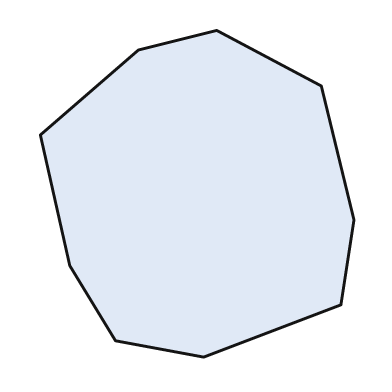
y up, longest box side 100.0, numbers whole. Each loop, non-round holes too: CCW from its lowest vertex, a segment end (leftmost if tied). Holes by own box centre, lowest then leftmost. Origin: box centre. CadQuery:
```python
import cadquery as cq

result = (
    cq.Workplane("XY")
    .moveTo(2.0, -50.0)
    .lineTo(44.0, -34.0)
    .lineTo(48.0, -8.0)
    .lineTo(38.0, 33.0)
    .lineTo(6.0, 50.0)
    .lineTo(-18.0, 44.0)
    .lineTo(-48.0, 18.0)
    .lineTo(-39.0, -22.0)
    .lineTo(-25.0, -45.0)
    .close()
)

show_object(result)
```